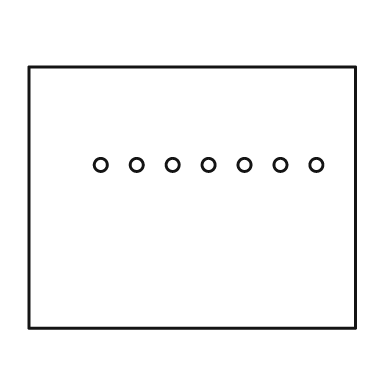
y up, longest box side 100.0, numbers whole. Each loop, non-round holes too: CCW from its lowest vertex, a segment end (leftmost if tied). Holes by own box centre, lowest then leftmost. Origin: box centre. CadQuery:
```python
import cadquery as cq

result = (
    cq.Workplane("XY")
    .moveTo(-50.0, -40.0)
    .lineTo(50.0, -40.0)
    .lineTo(50.0, 40.0)
    .lineTo(-50.0, 40.0)
    .close()
    .moveTo(-28.0, 10.0)
    .circle(2.0)
    .moveTo(-17.0, 10.0)
    .circle(2.0)
    .moveTo(-6.0, 10.0)
    .circle(2.0)
    .moveTo(5.0, 10.0)
    .circle(2.0)
    .moveTo(16.0, 10.0)
    .circle(2.0)
    .moveTo(27.0, 10.0)
    .circle(2.0)
    .moveTo(38.0, 10.0)
    .circle(2.0)
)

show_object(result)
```